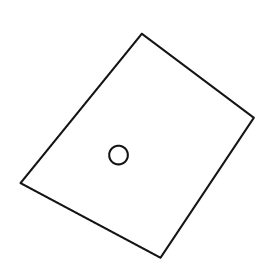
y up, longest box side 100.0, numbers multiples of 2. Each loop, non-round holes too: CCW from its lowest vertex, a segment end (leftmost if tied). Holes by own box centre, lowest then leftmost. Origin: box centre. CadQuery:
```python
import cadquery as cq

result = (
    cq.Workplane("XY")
    .moveTo(10.0, -48.0)
    .lineTo(50.0, 12.0)
    .lineTo(2.0, 48.0)
    .lineTo(-50.0, -16.0)
    .close()
    .moveTo(-8.0, -4.0)
    .circle(4.0)
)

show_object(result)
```